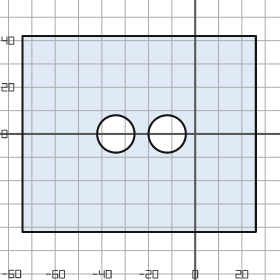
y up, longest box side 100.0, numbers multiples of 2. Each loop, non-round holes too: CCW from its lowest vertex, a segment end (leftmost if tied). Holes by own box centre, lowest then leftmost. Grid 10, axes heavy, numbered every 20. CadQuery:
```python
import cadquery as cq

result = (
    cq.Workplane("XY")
    .moveTo(-74.0, -42.0)
    .lineTo(26.0, -42.0)
    .lineTo(26.0, 42.0)
    .lineTo(-74.0, 42.0)
    .close()
    .moveTo(-34.0, 0.0)
    .circle(8.0)
    .moveTo(-12.0, 0.0)
    .circle(8.0)
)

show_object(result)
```